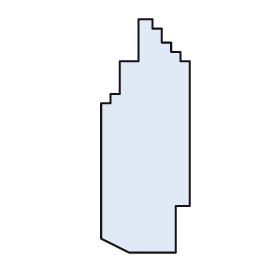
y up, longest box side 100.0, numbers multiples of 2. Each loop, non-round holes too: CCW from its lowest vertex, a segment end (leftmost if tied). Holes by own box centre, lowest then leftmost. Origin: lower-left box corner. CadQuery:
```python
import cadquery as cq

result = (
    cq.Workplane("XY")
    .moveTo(12.0, 0.0)
    .lineTo(32.0, 0.0)
    .lineTo(32.0, 20.0)
    .lineTo(38.0, 20.0)
    .lineTo(38.0, 82.0)
    .lineTo(34.0, 82.0)
    .lineTo(34.0, 86.0)
    .lineTo(30.0, 86.0)
    .lineTo(30.0, 90.0)
    .lineTo(26.0, 90.0)
    .lineTo(26.0, 96.0)
    .lineTo(22.0, 96.0)
    .lineTo(22.0, 100.0)
    .lineTo(16.0, 100.0)
    .lineTo(16.0, 82.0)
    .lineTo(8.0, 82.0)
    .lineTo(8.0, 68.0)
    .lineTo(4.0, 68.0)
    .lineTo(4.0, 64.0)
    .lineTo(0.0, 64.0)
    .lineTo(0.0, 6.0)
    .close()
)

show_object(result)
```